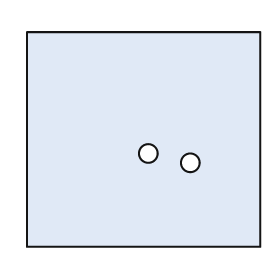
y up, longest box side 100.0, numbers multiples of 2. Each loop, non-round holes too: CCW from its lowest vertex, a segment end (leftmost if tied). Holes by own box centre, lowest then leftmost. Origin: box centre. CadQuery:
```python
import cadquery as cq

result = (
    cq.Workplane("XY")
    .moveTo(-50.0, -46.0)
    .lineTo(50.0, -46.0)
    .lineTo(50.0, 46.0)
    .lineTo(-50.0, 46.0)
    .close()
    .moveTo(20.0, -10.0)
    .circle(4.0)
    .moveTo(2.0, -6.0)
    .circle(4.0)
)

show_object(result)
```